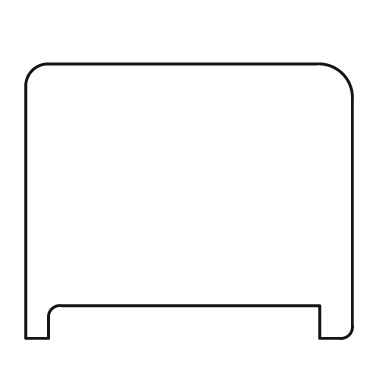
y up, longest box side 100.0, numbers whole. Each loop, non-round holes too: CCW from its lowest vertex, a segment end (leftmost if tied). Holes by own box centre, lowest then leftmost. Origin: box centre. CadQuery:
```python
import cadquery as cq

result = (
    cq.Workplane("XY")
    .moveTo(-50.0, -42.0)
    .lineTo(-43.0, -42.0)
    .lineTo(-43.0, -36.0)
    .threePointArc((-42.0, -33.0), (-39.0, -32.0))
    .lineTo(40.0, -32.0)
    .lineTo(40.0, -42.0)
    .lineTo(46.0, -42.0)
    .threePointArc((49.0, -41.0), (50.0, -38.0))
    .lineTo(50.0, 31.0)
    .threePointArc((47.0, 39.0), (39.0, 42.0))
    .lineTo(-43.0, 42.0)
    .threePointArc((-48.0, 40.0), (-50.0, 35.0))
    .close()
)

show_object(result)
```